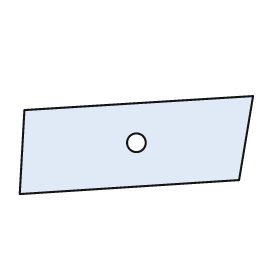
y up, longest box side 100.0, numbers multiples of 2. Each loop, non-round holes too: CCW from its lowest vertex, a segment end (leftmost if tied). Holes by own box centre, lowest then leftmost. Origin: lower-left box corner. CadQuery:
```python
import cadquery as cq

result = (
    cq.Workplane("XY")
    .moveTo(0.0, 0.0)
    .lineTo(94.0, 6.0)
    .lineTo(100.0, 42.0)
    .lineTo(2.0, 36.0)
    .close()
    .moveTo(50.0, 22.0)
    .circle(4.0)
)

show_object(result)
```